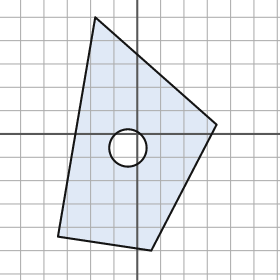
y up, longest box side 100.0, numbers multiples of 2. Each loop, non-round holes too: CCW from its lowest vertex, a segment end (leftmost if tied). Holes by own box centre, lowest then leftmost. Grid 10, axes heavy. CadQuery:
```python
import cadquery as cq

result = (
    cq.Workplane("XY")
    .moveTo(6.0, -50.0)
    .lineTo(34.0, 4.0)
    .lineTo(-18.0, 50.0)
    .lineTo(-34.0, -44.0)
    .close()
    .moveTo(-4.0, -6.0)
    .circle(8.0)
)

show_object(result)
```